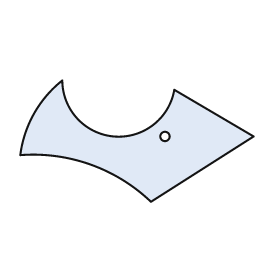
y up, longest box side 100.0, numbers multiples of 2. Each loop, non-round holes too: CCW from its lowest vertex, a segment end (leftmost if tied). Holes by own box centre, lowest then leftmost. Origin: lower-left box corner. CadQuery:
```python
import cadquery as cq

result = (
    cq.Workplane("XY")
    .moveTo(56.0, 0.0)
    .lineTo(100.0, 28.0)
    .lineTo(66.0, 48.0)
    .threePointArc((40.0, 28.0), (18.0, 52.0))
    .threePointArc((6.0, 38.0), (0.0, 20.0))
    .threePointArc((30.0, 16.0), (56.0, 0.0))
    .close()
    .moveTo(62.0, 28.0)
    .circle(2.0)
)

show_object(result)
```